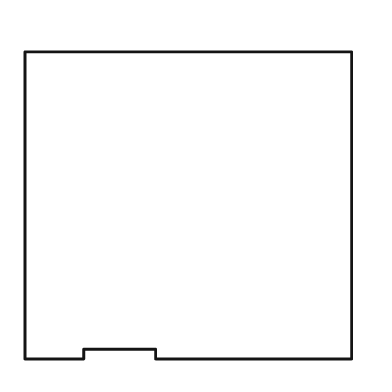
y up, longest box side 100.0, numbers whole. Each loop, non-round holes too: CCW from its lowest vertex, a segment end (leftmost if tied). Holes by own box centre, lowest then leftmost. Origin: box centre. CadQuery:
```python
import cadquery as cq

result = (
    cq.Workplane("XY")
    .moveTo(-50.0, -47.0)
    .lineTo(-32.0, -47.0)
    .lineTo(-32.0, -44.0)
    .lineTo(-10.0, -44.0)
    .lineTo(-10.0, -47.0)
    .lineTo(50.0, -47.0)
    .lineTo(50.0, 47.0)
    .lineTo(-50.0, 47.0)
    .close()
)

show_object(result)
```